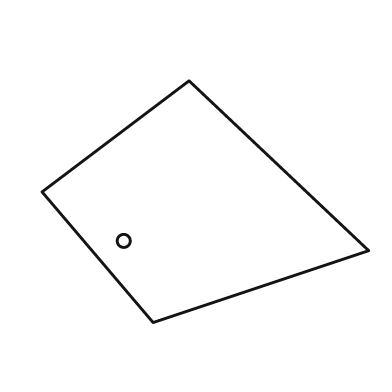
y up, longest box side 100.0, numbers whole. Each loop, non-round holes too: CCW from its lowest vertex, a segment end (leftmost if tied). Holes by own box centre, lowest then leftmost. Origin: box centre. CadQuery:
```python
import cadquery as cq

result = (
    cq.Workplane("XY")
    .moveTo(-16.0, -37.0)
    .lineTo(50.0, -15.0)
    .lineTo(-5.0, 37.0)
    .lineTo(-50.0, 3.0)
    .close()
    .moveTo(-25.0, -12.0)
    .circle(2.0)
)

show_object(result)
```